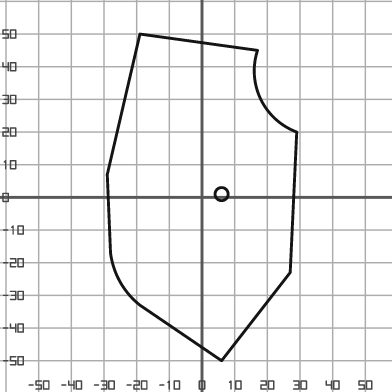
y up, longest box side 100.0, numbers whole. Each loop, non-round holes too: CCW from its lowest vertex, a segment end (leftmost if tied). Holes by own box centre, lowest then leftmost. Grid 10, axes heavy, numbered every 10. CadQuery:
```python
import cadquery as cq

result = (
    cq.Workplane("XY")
    .moveTo(6.0, -50.0)
    .lineTo(27.0, -23.0)
    .lineTo(29.0, 20.0)
    .threePointArc((18.0, 30.0), (17.0, 45.0))
    .lineTo(-19.0, 50.0)
    .lineTo(-29.0, 7.0)
    .lineTo(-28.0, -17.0)
    .threePointArc((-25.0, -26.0), (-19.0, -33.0))
    .close()
    .moveTo(6.0, 1.0)
    .circle(2.0)
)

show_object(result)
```